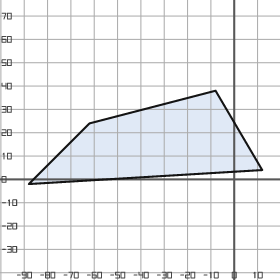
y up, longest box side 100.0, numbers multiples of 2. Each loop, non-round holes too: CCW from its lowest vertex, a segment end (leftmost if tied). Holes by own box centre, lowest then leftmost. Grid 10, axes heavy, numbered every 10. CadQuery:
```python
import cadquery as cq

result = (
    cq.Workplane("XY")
    .moveTo(-88.0, -2.0)
    .lineTo(12.0, 4.0)
    .lineTo(-8.0, 38.0)
    .lineTo(-62.0, 24.0)
    .close()
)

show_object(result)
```